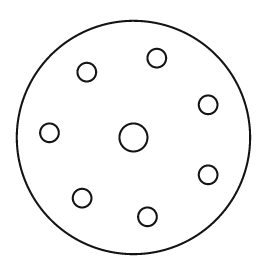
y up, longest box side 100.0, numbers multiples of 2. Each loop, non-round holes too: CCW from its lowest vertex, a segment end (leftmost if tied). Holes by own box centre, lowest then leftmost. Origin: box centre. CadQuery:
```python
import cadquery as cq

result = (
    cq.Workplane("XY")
    .moveTo(0.0, 0.0)
    .circle(50.0)
    .moveTo(6.0, -34.0)
    .circle(4.0)
    .moveTo(-22.0, -26.0)
    .circle(4.0)
    .moveTo(32.0, -16.0)
    .circle(4.0)
    .moveTo(0.0, 0.0)
    .circle(6.0)
    .moveTo(-36.0, 2.0)
    .circle(4.0)
    .moveTo(32.0, 14.0)
    .circle(4.0)
    .moveTo(-20.0, 28.0)
    .circle(4.0)
    .moveTo(10.0, 34.0)
    .circle(4.0)
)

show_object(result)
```